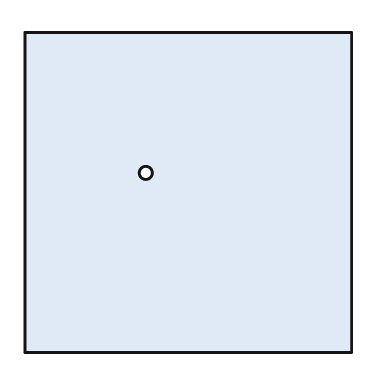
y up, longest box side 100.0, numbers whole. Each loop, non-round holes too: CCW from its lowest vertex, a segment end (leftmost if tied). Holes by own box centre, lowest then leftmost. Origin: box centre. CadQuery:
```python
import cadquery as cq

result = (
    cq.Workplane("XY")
    .moveTo(-50.0, -49.0)
    .lineTo(50.0, -49.0)
    .lineTo(50.0, 49.0)
    .lineTo(-50.0, 49.0)
    .close()
    .moveTo(-13.0, 6.0)
    .circle(2.0)
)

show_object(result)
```